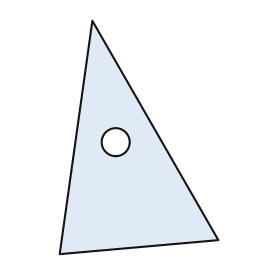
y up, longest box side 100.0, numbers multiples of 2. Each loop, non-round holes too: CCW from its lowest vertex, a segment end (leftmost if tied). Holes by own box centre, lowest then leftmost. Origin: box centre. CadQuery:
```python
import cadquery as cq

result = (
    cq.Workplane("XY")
    .moveTo(-34.0, -50.0)
    .lineTo(34.0, -44.0)
    .lineTo(-20.0, 50.0)
    .close()
    .moveTo(-10.0, -2.0)
    .circle(6.0)
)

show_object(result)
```